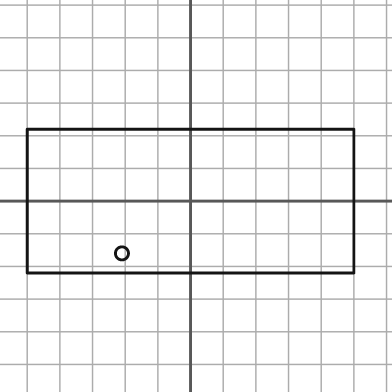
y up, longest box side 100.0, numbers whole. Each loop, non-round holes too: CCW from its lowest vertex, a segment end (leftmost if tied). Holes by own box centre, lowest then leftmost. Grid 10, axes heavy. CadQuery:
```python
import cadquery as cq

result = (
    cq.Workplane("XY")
    .moveTo(-50.0, -22.0)
    .lineTo(50.0, -22.0)
    .lineTo(50.0, 22.0)
    .lineTo(-50.0, 22.0)
    .close()
    .moveTo(-21.0, -16.0)
    .circle(2.0)
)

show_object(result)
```